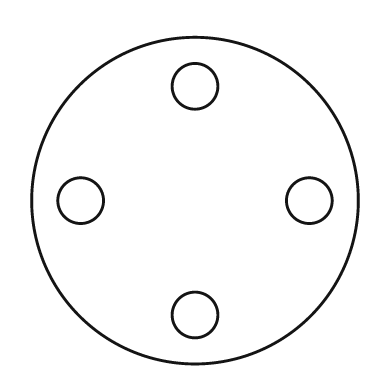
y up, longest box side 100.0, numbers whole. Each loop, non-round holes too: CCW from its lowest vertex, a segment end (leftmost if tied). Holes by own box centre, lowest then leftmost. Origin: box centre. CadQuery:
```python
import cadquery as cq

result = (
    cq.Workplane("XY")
    .moveTo(0.0, 0.0)
    .circle(50.0)
    .moveTo(0.0, -35.0)
    .circle(7.0)
    .moveTo(-35.0, 0.0)
    .circle(7.0)
    .moveTo(35.0, 0.0)
    .circle(7.0)
    .moveTo(0.0, 35.0)
    .circle(7.0)
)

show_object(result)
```